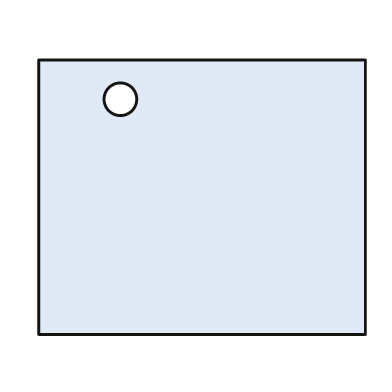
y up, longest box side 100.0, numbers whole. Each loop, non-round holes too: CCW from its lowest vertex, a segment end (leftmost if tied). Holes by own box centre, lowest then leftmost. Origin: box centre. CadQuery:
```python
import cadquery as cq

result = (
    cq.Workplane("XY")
    .moveTo(-50.0, -42.0)
    .lineTo(50.0, -42.0)
    .lineTo(50.0, 42.0)
    .lineTo(-50.0, 42.0)
    .close()
    .moveTo(-25.0, 30.0)
    .circle(5.0)
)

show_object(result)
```